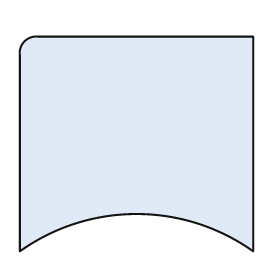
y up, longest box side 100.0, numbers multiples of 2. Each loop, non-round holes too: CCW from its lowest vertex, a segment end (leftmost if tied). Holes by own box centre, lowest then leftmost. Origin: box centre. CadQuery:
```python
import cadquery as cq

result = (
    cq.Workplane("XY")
    .moveTo(-50.0, -46.0)
    .threePointArc((0.0, -30.0), (50.0, -46.0))
    .lineTo(50.0, 46.0)
    .lineTo(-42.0, 46.0)
    .threePointArc((-48.0, 44.0), (-50.0, 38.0))
    .close()
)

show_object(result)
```